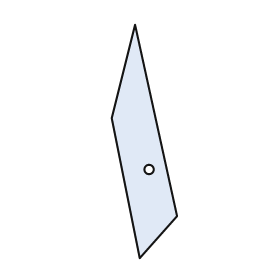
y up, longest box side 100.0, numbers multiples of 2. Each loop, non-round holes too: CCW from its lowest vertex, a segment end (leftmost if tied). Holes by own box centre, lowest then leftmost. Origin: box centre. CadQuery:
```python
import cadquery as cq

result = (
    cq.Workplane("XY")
    .moveTo(-2.0, -50.0)
    .lineTo(14.0, -32.0)
    .lineTo(-4.0, 50.0)
    .lineTo(-14.0, 10.0)
    .close()
    .moveTo(2.0, -12.0)
    .circle(2.0)
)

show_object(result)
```